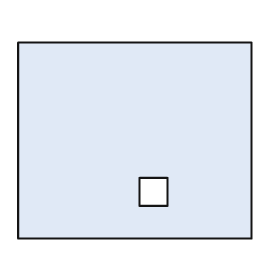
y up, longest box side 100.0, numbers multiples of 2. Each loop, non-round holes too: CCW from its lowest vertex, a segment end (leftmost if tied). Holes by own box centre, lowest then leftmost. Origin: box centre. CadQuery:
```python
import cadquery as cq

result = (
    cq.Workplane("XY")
    .moveTo(-50.0, -42.0)
    .lineTo(50.0, -42.0)
    .lineTo(50.0, 42.0)
    .lineTo(-50.0, 42.0)
    .close()
    .moveTo(2.0, -28.0)
    .lineTo(14.0, -28.0)
    .lineTo(14.0, -16.0)
    .lineTo(2.0, -16.0)
    .close()
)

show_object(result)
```